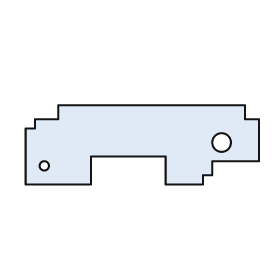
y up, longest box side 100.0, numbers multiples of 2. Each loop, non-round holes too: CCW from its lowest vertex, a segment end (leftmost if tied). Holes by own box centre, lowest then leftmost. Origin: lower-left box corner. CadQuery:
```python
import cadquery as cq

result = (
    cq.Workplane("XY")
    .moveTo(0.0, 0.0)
    .lineTo(28.0, 0.0)
    .lineTo(28.0, 12.0)
    .lineTo(60.0, 12.0)
    .lineTo(60.0, 0.0)
    .lineTo(76.0, 0.0)
    .lineTo(76.0, 4.0)
    .lineTo(80.0, 4.0)
    .lineTo(80.0, 10.0)
    .lineTo(100.0, 10.0)
    .lineTo(100.0, 28.0)
    .lineTo(94.0, 28.0)
    .lineTo(94.0, 34.0)
    .lineTo(14.0, 34.0)
    .lineTo(14.0, 28.0)
    .lineTo(4.0, 28.0)
    .lineTo(4.0, 24.0)
    .lineTo(0.0, 24.0)
    .close()
    .moveTo(8.0, 8.0)
    .circle(2.0)
    .moveTo(84.0, 18.0)
    .circle(4.0)
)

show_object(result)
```